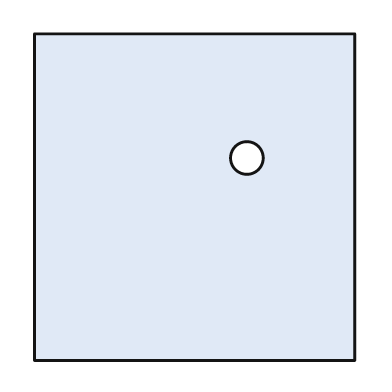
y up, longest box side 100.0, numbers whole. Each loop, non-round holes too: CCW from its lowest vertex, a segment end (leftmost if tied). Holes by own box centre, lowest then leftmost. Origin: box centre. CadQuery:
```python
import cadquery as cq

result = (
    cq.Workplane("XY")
    .moveTo(-49.0, -50.0)
    .lineTo(49.0, -50.0)
    .lineTo(49.0, 50.0)
    .lineTo(-49.0, 50.0)
    .close()
    .moveTo(16.0, 12.0)
    .circle(5.0)
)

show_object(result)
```